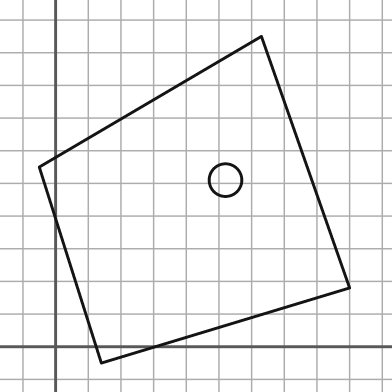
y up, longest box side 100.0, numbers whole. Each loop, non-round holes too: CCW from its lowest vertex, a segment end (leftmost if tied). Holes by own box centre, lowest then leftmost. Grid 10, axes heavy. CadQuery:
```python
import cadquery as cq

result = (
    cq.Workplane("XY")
    .moveTo(14.0, -5.0)
    .lineTo(90.0, 18.0)
    .lineTo(63.0, 95.0)
    .lineTo(-5.0, 55.0)
    .close()
    .moveTo(52.0, 51.0)
    .circle(5.0)
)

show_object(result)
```